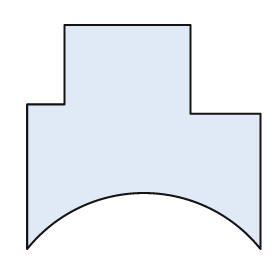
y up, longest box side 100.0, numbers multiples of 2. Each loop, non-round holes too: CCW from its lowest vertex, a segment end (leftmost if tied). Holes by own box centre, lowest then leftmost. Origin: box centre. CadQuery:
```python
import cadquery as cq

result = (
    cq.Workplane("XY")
    .moveTo(-50.0, -48.0)
    .threePointArc((0.0, -24.0), (50.0, -48.0))
    .lineTo(50.0, 10.0)
    .lineTo(20.0, 10.0)
    .lineTo(20.0, 48.0)
    .lineTo(-34.0, 48.0)
    .lineTo(-34.0, 14.0)
    .lineTo(-50.0, 14.0)
    .close()
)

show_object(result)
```